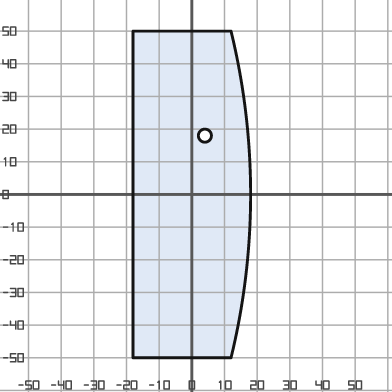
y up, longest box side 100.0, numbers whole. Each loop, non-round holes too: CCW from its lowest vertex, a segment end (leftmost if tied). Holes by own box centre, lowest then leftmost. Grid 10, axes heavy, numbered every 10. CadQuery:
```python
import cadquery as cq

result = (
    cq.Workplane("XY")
    .moveTo(-18.0, -50.0)
    .lineTo(12.0, -50.0)
    .threePointArc((18.0, 0.0), (12.0, 50.0))
    .lineTo(-18.0, 50.0)
    .close()
    .moveTo(4.0, 18.0)
    .circle(2.0)
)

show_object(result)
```